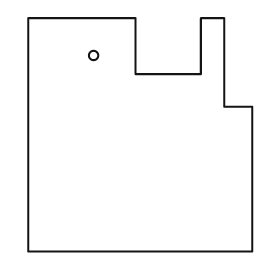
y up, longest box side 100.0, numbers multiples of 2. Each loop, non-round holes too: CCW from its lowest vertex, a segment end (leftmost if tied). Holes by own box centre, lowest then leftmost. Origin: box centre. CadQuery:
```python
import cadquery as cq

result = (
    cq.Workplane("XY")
    .moveTo(-48.0, -50.0)
    .lineTo(48.0, -50.0)
    .lineTo(48.0, 12.0)
    .lineTo(36.0, 12.0)
    .lineTo(36.0, 50.0)
    .lineTo(26.0, 50.0)
    .lineTo(26.0, 26.0)
    .lineTo(-2.0, 26.0)
    .lineTo(-2.0, 50.0)
    .lineTo(-48.0, 50.0)
    .close()
    .moveTo(-20.0, 34.0)
    .circle(2.0)
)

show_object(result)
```